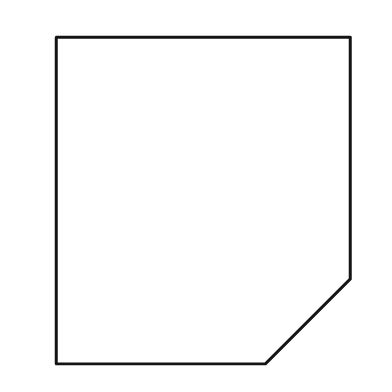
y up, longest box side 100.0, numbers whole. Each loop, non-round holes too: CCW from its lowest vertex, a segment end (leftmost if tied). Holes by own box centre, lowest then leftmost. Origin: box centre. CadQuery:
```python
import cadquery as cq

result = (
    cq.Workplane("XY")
    .moveTo(-45.0, -50.0)
    .lineTo(19.0, -50.0)
    .lineTo(45.0, -24.0)
    .lineTo(45.0, 50.0)
    .lineTo(-45.0, 50.0)
    .close()
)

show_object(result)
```